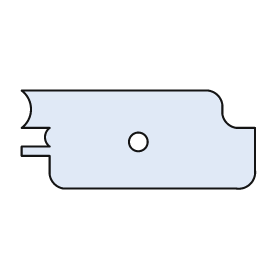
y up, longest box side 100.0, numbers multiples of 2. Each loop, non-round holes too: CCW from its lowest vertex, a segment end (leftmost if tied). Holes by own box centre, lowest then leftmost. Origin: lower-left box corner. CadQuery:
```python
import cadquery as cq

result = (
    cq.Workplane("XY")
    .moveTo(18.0, 0.0)
    .lineTo(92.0, 0.0)
    .threePointArc((98.0, 2.0), (100.0, 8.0))
    .lineTo(100.0, 26.0)
    .lineTo(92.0, 26.0)
    .threePointArc((88.0, 28.0), (86.0, 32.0))
    .lineTo(86.0, 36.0)
    .threePointArc((84.0, 40.0), (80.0, 42.0))
    .lineTo(0.0, 42.0)
    .threePointArc((4.0, 34.0), (0.0, 26.0))
    .lineTo(12.0, 26.0)
    .threePointArc((10.0, 22.0), (12.0, 18.0))
    .lineTo(0.0, 18.0)
    .lineTo(0.0, 14.0)
    .lineTo(12.0, 14.0)
    .lineTo(12.0, 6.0)
    .threePointArc((14.0, 2.0), (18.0, 0.0))
    .close()
    .moveTo(50.0, 20.0)
    .circle(4.0)
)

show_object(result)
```